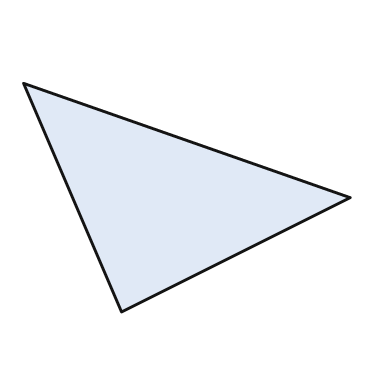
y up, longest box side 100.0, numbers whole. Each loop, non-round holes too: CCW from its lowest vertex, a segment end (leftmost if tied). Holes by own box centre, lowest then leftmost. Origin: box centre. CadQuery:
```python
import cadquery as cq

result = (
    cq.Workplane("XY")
    .moveTo(-20.0, -35.0)
    .lineTo(50.0, 0.0)
    .lineTo(-50.0, 35.0)
    .close()
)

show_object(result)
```